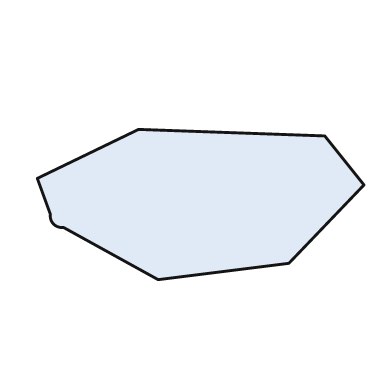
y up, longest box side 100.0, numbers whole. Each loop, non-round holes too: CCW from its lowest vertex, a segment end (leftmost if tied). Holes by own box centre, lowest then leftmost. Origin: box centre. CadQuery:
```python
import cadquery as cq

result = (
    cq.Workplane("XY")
    .moveTo(-13.0, -23.0)
    .lineTo(27.0, -18.0)
    .lineTo(50.0, 6.0)
    .lineTo(38.0, 21.0)
    .lineTo(-19.0, 23.0)
    .lineTo(-50.0, 8.0)
    .lineTo(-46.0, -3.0)
    .threePointArc((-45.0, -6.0), (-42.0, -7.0))
    .close()
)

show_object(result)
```